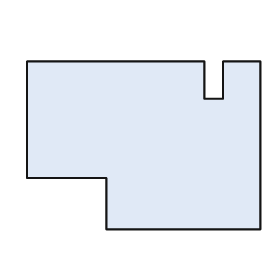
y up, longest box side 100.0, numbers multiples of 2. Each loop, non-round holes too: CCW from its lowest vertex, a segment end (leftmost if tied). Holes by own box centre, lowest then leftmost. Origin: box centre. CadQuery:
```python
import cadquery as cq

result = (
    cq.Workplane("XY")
    .moveTo(-16.0, -36.0)
    .lineTo(50.0, -36.0)
    .lineTo(50.0, 36.0)
    .lineTo(34.0, 36.0)
    .lineTo(34.0, 20.0)
    .lineTo(26.0, 20.0)
    .lineTo(26.0, 36.0)
    .lineTo(-50.0, 36.0)
    .lineTo(-50.0, -14.0)
    .lineTo(-16.0, -14.0)
    .close()
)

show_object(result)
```